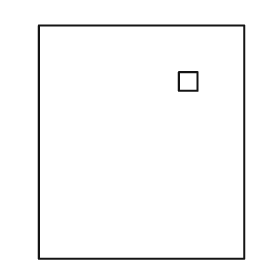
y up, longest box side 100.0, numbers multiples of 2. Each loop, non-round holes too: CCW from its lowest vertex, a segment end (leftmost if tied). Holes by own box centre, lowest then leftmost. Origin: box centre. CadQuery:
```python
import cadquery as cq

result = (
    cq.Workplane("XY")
    .moveTo(-44.0, -50.0)
    .lineTo(44.0, -50.0)
    .lineTo(44.0, 50.0)
    .lineTo(-44.0, 50.0)
    .close()
    .moveTo(16.0, 22.0)
    .lineTo(24.0, 22.0)
    .lineTo(24.0, 30.0)
    .lineTo(16.0, 30.0)
    .close()
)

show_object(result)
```